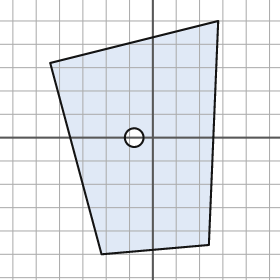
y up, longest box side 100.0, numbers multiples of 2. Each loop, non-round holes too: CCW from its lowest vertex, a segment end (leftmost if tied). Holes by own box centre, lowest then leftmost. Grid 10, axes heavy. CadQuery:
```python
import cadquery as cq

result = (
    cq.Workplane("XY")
    .moveTo(-22.0, -50.0)
    .lineTo(24.0, -46.0)
    .lineTo(28.0, 50.0)
    .lineTo(-44.0, 32.0)
    .close()
    .moveTo(-8.0, 0.0)
    .circle(4.0)
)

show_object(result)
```